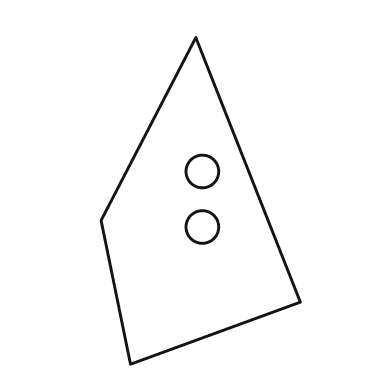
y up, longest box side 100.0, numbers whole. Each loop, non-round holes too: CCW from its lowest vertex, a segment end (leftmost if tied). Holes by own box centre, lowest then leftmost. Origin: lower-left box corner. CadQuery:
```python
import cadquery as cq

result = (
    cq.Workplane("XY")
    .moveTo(9.0, 0.0)
    .lineTo(61.0, 19.0)
    .lineTo(29.0, 100.0)
    .lineTo(0.0, 44.0)
    .close()
    .moveTo(31.0, 42.0)
    .circle(5.0)
    .moveTo(31.0, 59.0)
    .circle(5.0)
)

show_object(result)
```